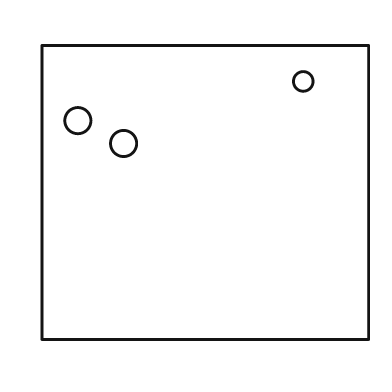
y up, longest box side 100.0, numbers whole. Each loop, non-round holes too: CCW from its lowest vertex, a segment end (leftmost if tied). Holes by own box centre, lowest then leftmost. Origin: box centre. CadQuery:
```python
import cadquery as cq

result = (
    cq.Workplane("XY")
    .moveTo(-50.0, -45.0)
    .lineTo(50.0, -45.0)
    .lineTo(50.0, 45.0)
    .lineTo(-50.0, 45.0)
    .close()
    .moveTo(-25.0, 15.0)
    .circle(4.0)
    .moveTo(-39.0, 22.0)
    .circle(4.0)
    .moveTo(30.0, 34.0)
    .circle(3.0)
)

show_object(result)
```